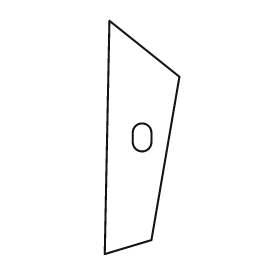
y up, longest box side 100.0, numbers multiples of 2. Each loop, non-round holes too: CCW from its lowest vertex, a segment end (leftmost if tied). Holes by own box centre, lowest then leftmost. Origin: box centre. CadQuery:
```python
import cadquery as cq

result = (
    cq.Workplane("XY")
    .moveTo(-16.0, -50.0)
    .lineTo(4.0, -44.0)
    .lineTo(16.0, 26.0)
    .lineTo(-14.0, 50.0)
    .close()
    .moveTo(-4.0, -2.0)
    .threePointArc((0.0, -6.0), (4.0, -2.0))
    .lineTo(4.0, 2.0)
    .threePointArc((0.0, 6.0), (-4.0, 2.0))
    .close()
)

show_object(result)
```